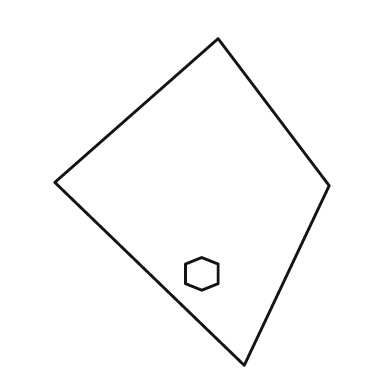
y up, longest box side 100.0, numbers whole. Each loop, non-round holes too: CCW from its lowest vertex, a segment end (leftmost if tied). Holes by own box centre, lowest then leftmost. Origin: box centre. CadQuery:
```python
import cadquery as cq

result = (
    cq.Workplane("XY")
    .moveTo(16.0, -50.0)
    .lineTo(42.0, 5.0)
    .lineTo(8.0, 50.0)
    .lineTo(-42.0, 6.0)
    .close()
    .moveTo(3.0, -27.0)
    .lineTo(8.0, -25.0)
    .lineTo(8.0, -19.0)
    .lineTo(3.0, -17.0)
    .lineTo(-2.0, -19.0)
    .lineTo(-2.0, -25.0)
    .close()
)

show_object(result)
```